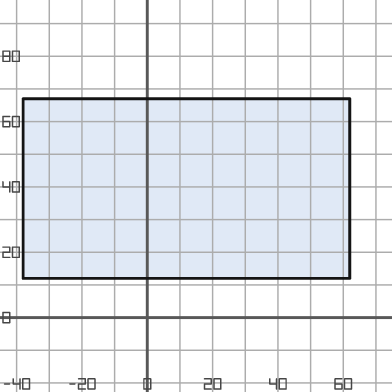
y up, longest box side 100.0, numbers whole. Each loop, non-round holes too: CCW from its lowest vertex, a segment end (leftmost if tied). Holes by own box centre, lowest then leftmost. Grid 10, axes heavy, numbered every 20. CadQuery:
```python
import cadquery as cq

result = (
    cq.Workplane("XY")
    .moveTo(-38.0, 12.0)
    .lineTo(62.0, 12.0)
    .lineTo(62.0, 67.0)
    .lineTo(-38.0, 67.0)
    .close()
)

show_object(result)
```